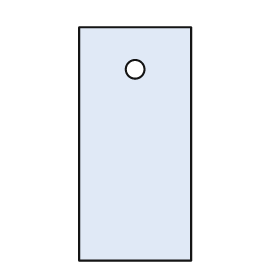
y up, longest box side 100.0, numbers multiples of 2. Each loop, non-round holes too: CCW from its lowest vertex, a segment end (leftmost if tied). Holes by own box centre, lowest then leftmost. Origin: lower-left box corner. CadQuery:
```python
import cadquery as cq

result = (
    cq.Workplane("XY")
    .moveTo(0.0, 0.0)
    .lineTo(48.0, 0.0)
    .lineTo(48.0, 100.0)
    .lineTo(0.0, 100.0)
    .close()
    .moveTo(24.0, 82.0)
    .circle(4.0)
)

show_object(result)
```